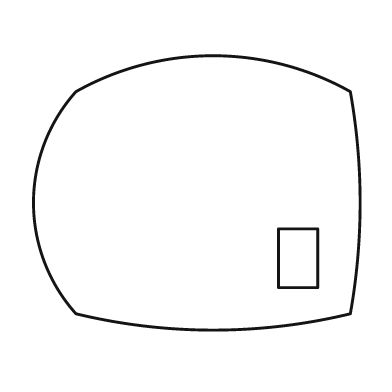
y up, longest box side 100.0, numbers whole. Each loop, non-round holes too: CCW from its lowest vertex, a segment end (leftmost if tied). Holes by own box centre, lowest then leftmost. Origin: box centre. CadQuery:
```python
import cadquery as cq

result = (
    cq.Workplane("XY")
    .moveTo(-37.0, -37.0)
    .threePointArc((5.0, -42.0), (47.0, -37.0))
    .threePointArc((50.0, -3.0), (47.0, 31.0))
    .threePointArc((5.0, 42.0), (-37.0, 31.0))
    .threePointArc((-50.0, -3.0), (-37.0, -37.0))
    .close()
    .moveTo(25.0, -29.0)
    .lineTo(37.0, -29.0)
    .lineTo(37.0, -11.0)
    .lineTo(25.0, -11.0)
    .close()
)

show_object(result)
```